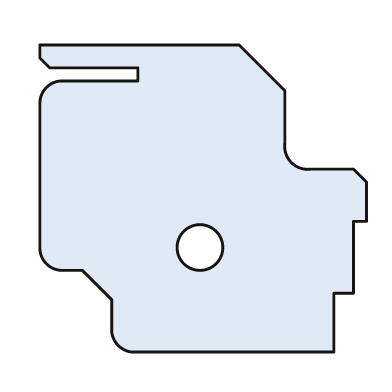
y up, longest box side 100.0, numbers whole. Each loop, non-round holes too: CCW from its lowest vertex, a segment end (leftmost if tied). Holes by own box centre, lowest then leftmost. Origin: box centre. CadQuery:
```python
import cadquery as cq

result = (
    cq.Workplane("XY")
    .moveTo(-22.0, -47.0)
    .lineTo(40.0, -47.0)
    .lineTo(40.0, -29.0)
    .lineTo(46.0, -29.0)
    .lineTo(46.0, -7.0)
    .lineTo(50.0, -7.0)
    .lineTo(50.0, 5.0)
    .lineTo(46.0, 9.0)
    .lineTo(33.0, 9.0)
    .threePointArc((27.0, 11.0), (25.0, 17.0))
    .lineTo(25.0, 33.0)
    .lineTo(11.0, 47.0)
    .lineTo(-50.0, 47.0)
    .lineTo(-50.0, 43.0)
    .lineTo(-47.0, 40.0)
    .lineTo(-20.0, 40.0)
    .lineTo(-20.0, 36.0)
    .lineTo(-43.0, 36.0)
    .threePointArc((-48.0, 34.0), (-50.0, 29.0))
    .lineTo(-50.0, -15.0)
    .threePointArc((-48.0, -20.0), (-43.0, -22.0))
    .lineTo(-37.0, -22.0)
    .lineTo(-28.0, -31.0)
    .lineTo(-28.0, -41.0)
    .threePointArc((-26.0, -45.0), (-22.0, -47.0))
    .close()
    .moveTo(-1.0, -15.0)
    .circle(7.0)
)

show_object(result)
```